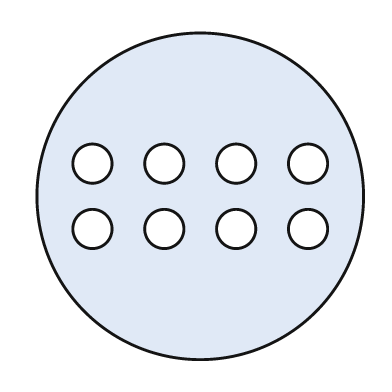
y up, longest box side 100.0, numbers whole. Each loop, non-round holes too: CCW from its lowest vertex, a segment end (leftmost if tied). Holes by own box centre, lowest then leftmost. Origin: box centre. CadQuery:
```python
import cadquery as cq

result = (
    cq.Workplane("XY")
    .moveTo(0.0, 0.0)
    .circle(50.0)
    .moveTo(-33.0, -10.0)
    .circle(6.0)
    .moveTo(-11.0, -10.0)
    .circle(6.0)
    .moveTo(11.0, -10.0)
    .circle(6.0)
    .moveTo(33.0, -10.0)
    .circle(6.0)
    .moveTo(-33.0, 10.0)
    .circle(6.0)
    .moveTo(-11.0, 10.0)
    .circle(6.0)
    .moveTo(11.0, 10.0)
    .circle(6.0)
    .moveTo(33.0, 10.0)
    .circle(6.0)
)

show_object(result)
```